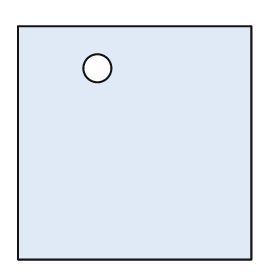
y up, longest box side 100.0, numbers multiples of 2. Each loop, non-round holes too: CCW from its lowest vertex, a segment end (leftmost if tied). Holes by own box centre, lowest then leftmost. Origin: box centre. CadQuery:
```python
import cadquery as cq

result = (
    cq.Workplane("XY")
    .moveTo(-50.0, -50.0)
    .lineTo(50.0, -50.0)
    .lineTo(50.0, 50.0)
    .lineTo(-50.0, 50.0)
    .close()
    .moveTo(-16.0, 32.0)
    .circle(6.0)
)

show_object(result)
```